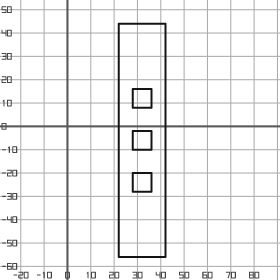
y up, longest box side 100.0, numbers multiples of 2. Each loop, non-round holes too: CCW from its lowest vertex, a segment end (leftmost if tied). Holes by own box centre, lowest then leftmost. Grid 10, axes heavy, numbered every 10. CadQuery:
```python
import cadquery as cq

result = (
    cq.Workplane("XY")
    .moveTo(22.0, -56.0)
    .lineTo(42.0, -56.0)
    .lineTo(42.0, 44.0)
    .lineTo(22.0, 44.0)
    .close()
    .moveTo(28.0, -28.0)
    .lineTo(36.0, -28.0)
    .lineTo(36.0, -20.0)
    .lineTo(28.0, -20.0)
    .close()
    .moveTo(28.0, -10.0)
    .lineTo(36.0, -10.0)
    .lineTo(36.0, -2.0)
    .lineTo(28.0, -2.0)
    .close()
    .moveTo(28.0, 8.0)
    .lineTo(36.0, 8.0)
    .lineTo(36.0, 16.0)
    .lineTo(28.0, 16.0)
    .close()
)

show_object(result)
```